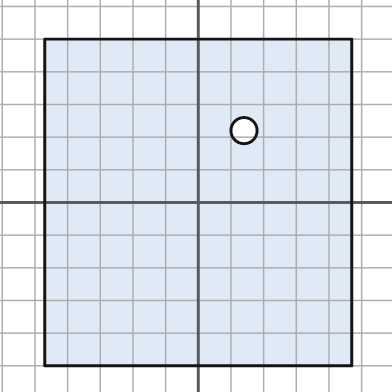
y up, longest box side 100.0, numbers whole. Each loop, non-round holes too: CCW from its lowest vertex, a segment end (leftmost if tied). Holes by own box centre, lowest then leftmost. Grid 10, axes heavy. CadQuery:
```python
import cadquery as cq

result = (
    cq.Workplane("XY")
    .moveTo(-47.0, -50.0)
    .lineTo(47.0, -50.0)
    .lineTo(47.0, 50.0)
    .lineTo(-47.0, 50.0)
    .close()
    .moveTo(14.0, 22.0)
    .circle(4.0)
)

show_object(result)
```